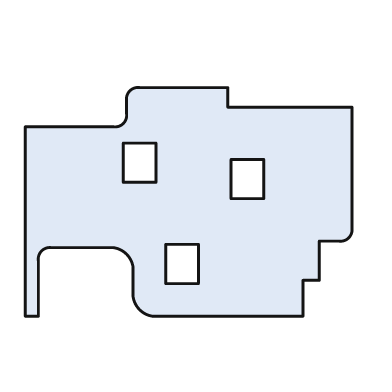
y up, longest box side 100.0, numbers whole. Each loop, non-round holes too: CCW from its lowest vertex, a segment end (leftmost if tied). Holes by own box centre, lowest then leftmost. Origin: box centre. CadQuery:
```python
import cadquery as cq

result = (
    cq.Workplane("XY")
    .moveTo(-50.0, -35.0)
    .lineTo(-46.0, -35.0)
    .lineTo(-46.0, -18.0)
    .threePointArc((-45.0, -15.0), (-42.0, -14.0))
    .lineTo(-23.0, -14.0)
    .threePointArc((-19.0, -16.0), (-17.0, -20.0))
    .lineTo(-17.0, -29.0)
    .threePointArc((-15.0, -33.0), (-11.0, -35.0))
    .lineTo(35.0, -35.0)
    .lineTo(35.0, -24.0)
    .lineTo(40.0, -24.0)
    .lineTo(40.0, -12.0)
    .lineTo(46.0, -12.0)
    .threePointArc((49.0, -11.0), (50.0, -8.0))
    .lineTo(50.0, 29.0)
    .lineTo(12.0, 29.0)
    .lineTo(12.0, 35.0)
    .lineTo(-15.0, 35.0)
    .threePointArc((-18.0, 34.0), (-19.0, 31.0))
    .lineTo(-19.0, 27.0)
    .threePointArc((-20.0, 24.0), (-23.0, 23.0))
    .lineTo(-50.0, 23.0)
    .close()
    .moveTo(-7.0, -25.0)
    .lineTo(3.0, -25.0)
    .lineTo(3.0, -13.0)
    .lineTo(-7.0, -13.0)
    .close()
    .moveTo(13.0, 1.0)
    .lineTo(23.0, 1.0)
    .lineTo(23.0, 13.0)
    .lineTo(13.0, 13.0)
    .close()
    .moveTo(-20.0, 6.0)
    .lineTo(-10.0, 6.0)
    .lineTo(-10.0, 18.0)
    .lineTo(-20.0, 18.0)
    .close()
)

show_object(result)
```